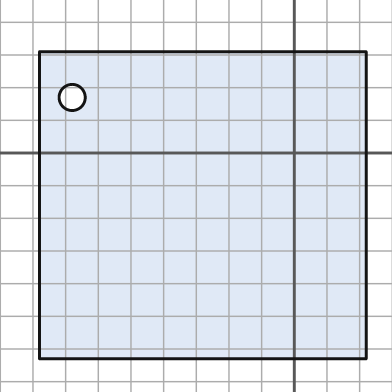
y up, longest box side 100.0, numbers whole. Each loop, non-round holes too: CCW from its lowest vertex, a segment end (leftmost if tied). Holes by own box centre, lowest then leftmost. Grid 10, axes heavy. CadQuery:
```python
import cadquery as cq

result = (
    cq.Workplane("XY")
    .moveTo(-78.0, -63.0)
    .lineTo(22.0, -63.0)
    .lineTo(22.0, 31.0)
    .lineTo(-78.0, 31.0)
    .close()
    .moveTo(-68.0, 17.0)
    .circle(4.0)
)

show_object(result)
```